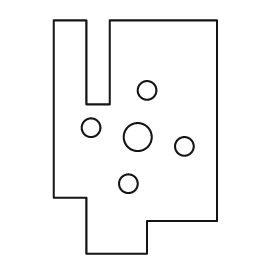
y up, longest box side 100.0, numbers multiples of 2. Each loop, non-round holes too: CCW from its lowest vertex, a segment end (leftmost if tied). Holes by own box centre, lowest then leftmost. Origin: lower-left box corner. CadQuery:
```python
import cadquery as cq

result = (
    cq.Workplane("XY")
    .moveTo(14.0, 0.0)
    .lineTo(40.0, 0.0)
    .lineTo(40.0, 14.0)
    .lineTo(70.0, 14.0)
    .lineTo(70.0, 100.0)
    .lineTo(24.0, 100.0)
    .lineTo(24.0, 64.0)
    .lineTo(14.0, 64.0)
    .lineTo(14.0, 100.0)
    .lineTo(0.0, 100.0)
    .lineTo(0.0, 24.0)
    .lineTo(14.0, 24.0)
    .close()
    .moveTo(32.0, 30.0)
    .circle(4.0)
    .moveTo(56.0, 46.0)
    .circle(4.0)
    .moveTo(36.0, 50.0)
    .circle(6.0)
    .moveTo(16.0, 54.0)
    .circle(4.0)
    .moveTo(40.0, 70.0)
    .circle(4.0)
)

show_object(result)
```